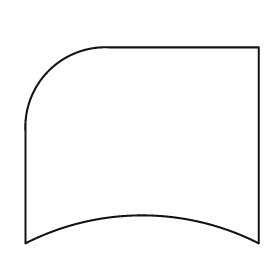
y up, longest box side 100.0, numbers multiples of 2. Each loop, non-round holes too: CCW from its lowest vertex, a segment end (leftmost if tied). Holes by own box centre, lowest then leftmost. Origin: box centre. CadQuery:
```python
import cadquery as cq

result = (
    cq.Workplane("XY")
    .moveTo(-50.0, -42.0)
    .threePointArc((0.0, -30.0), (50.0, -42.0))
    .lineTo(50.0, 42.0)
    .lineTo(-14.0, 42.0)
    .threePointArc((-40.0, 32.0), (-50.0, 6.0))
    .close()
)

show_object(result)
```